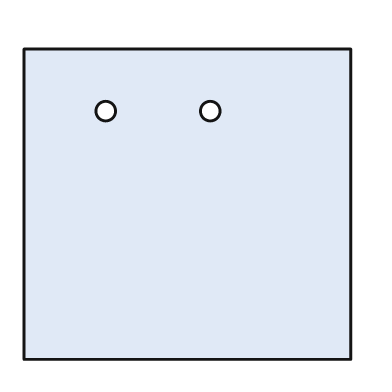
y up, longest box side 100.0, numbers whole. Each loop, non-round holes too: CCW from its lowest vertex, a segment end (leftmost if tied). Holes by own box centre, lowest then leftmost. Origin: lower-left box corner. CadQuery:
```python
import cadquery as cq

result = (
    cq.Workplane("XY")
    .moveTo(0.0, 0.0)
    .lineTo(100.0, 0.0)
    .lineTo(100.0, 95.0)
    .lineTo(0.0, 95.0)
    .close()
    .moveTo(25.0, 76.0)
    .circle(3.0)
    .moveTo(57.0, 76.0)
    .circle(3.0)
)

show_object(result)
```